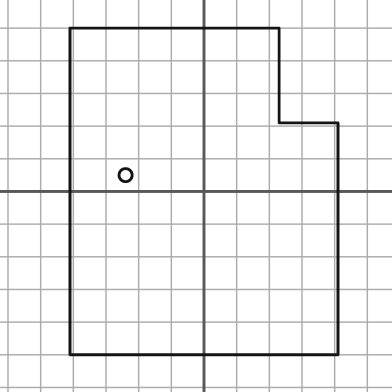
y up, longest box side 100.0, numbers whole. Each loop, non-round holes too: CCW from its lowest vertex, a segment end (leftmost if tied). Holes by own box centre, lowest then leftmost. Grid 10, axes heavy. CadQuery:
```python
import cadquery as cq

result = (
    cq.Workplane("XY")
    .moveTo(-41.0, -50.0)
    .lineTo(41.0, -50.0)
    .lineTo(41.0, 21.0)
    .lineTo(23.0, 21.0)
    .lineTo(23.0, 50.0)
    .lineTo(-41.0, 50.0)
    .close()
    .moveTo(-24.0, 5.0)
    .circle(2.0)
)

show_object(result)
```